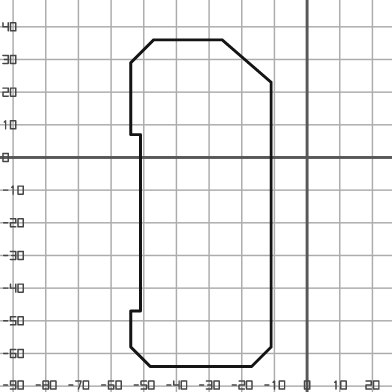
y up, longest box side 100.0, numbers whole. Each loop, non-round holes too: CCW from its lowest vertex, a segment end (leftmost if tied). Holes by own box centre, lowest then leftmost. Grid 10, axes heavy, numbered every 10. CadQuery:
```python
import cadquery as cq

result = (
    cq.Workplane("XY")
    .moveTo(-48.0, -64.0)
    .lineTo(-17.0, -64.0)
    .lineTo(-11.0, -58.0)
    .lineTo(-11.0, 23.0)
    .lineTo(-26.0, 36.0)
    .lineTo(-47.0, 36.0)
    .lineTo(-54.0, 29.0)
    .lineTo(-54.0, 7.0)
    .lineTo(-51.0, 7.0)
    .lineTo(-51.0, -47.0)
    .lineTo(-54.0, -47.0)
    .lineTo(-54.0, -58.0)
    .close()
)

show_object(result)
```